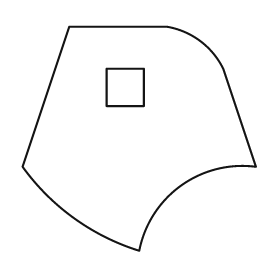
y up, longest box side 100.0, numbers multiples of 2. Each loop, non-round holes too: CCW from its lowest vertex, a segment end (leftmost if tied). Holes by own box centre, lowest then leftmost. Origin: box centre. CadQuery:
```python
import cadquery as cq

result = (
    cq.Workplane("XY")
    .moveTo(0.0, -48.0)
    .threePointArc((18.0, -20.0), (50.0, -12.0))
    .lineTo(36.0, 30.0)
    .threePointArc((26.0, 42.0), (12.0, 48.0))
    .lineTo(-30.0, 48.0)
    .lineTo(-50.0, -12.0)
    .threePointArc((-28.0, -34.0), (0.0, -48.0))
    .close()
    .moveTo(-14.0, 14.0)
    .lineTo(2.0, 14.0)
    .lineTo(2.0, 30.0)
    .lineTo(-14.0, 30.0)
    .close()
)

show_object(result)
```